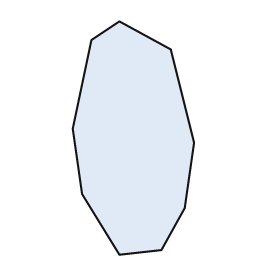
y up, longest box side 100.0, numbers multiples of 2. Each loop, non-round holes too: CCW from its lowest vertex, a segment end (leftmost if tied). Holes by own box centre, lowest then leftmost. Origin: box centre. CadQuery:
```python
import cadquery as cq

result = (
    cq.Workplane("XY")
    .moveTo(-6.0, -50.0)
    .lineTo(12.0, -48.0)
    .lineTo(22.0, -30.0)
    .lineTo(26.0, -2.0)
    .lineTo(16.0, 38.0)
    .lineTo(-6.0, 50.0)
    .lineTo(-18.0, 42.0)
    .lineTo(-26.0, 4.0)
    .lineTo(-22.0, -24.0)
    .close()
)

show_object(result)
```